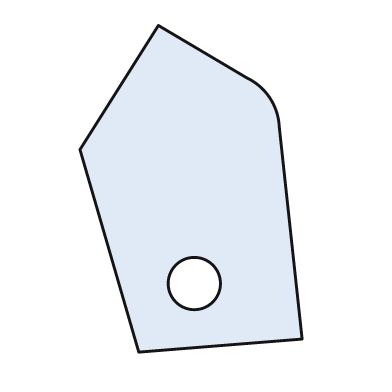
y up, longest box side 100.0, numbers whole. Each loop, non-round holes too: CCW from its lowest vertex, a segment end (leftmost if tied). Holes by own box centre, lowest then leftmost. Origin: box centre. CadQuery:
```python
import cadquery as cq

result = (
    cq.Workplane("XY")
    .moveTo(-16.0, -50.0)
    .lineTo(34.0, -46.0)
    .lineTo(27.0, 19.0)
    .threePointArc((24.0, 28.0), (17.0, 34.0))
    .lineTo(-10.0, 50.0)
    .lineTo(-34.0, 12.0)
    .close()
    .moveTo(1.0, -29.0)
    .circle(8.0)
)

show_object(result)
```